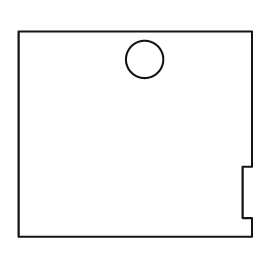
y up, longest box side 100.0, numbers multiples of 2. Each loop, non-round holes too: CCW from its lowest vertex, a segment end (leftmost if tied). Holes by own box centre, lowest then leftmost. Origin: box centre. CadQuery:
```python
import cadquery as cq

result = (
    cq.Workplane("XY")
    .moveTo(-50.0, -44.0)
    .lineTo(50.0, -44.0)
    .lineTo(50.0, -36.0)
    .lineTo(46.0, -36.0)
    .lineTo(46.0, -14.0)
    .lineTo(50.0, -14.0)
    .lineTo(50.0, 44.0)
    .lineTo(-50.0, 44.0)
    .close()
    .moveTo(4.0, 32.0)
    .circle(8.0)
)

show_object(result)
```